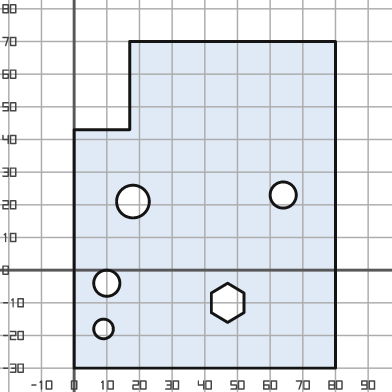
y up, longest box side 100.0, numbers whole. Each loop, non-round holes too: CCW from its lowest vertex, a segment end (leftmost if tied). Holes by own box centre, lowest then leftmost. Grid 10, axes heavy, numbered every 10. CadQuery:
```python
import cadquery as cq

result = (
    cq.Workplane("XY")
    .moveTo(0.0, -30.0)
    .lineTo(80.0, -30.0)
    .lineTo(80.0, 70.0)
    .lineTo(17.0, 70.0)
    .lineTo(17.0, 43.0)
    .lineTo(0.0, 43.0)
    .close()
    .moveTo(9.0, -18.0)
    .circle(3.0)
    .moveTo(47.0, -16.0)
    .lineTo(52.0, -13.0)
    .lineTo(52.0, -7.0)
    .lineTo(47.0, -4.0)
    .lineTo(42.0, -7.0)
    .lineTo(42.0, -13.0)
    .close()
    .moveTo(10.0, -4.0)
    .circle(4.0)
    .moveTo(18.0, 21.0)
    .circle(5.0)
    .moveTo(64.0, 23.0)
    .circle(4.0)
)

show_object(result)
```